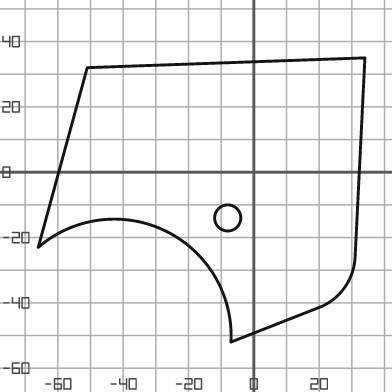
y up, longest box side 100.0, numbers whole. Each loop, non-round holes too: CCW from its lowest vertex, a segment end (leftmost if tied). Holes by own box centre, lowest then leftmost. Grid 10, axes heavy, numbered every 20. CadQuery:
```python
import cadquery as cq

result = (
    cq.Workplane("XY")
    .moveTo(-7.0, -52.0)
    .lineTo(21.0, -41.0)
    .threePointArc((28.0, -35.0), (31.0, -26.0))
    .lineTo(34.0, 35.0)
    .lineTo(-51.0, 32.0)
    .lineTo(-66.0, -23.0)
    .threePointArc((-27.0, -18.0), (-7.0, -52.0))
    .close()
    .moveTo(-8.0, -14.0)
    .circle(4.0)
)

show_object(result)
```